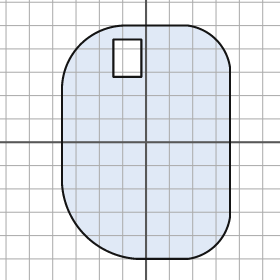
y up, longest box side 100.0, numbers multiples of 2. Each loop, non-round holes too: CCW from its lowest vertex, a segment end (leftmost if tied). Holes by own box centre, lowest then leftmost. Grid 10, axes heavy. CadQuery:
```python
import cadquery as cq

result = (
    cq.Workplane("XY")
    .moveTo(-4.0, -50.0)
    .lineTo(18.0, -50.0)
    .threePointArc((30.0, -44.0), (36.0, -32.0))
    .lineTo(36.0, 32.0)
    .threePointArc((30.0, 44.0), (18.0, 50.0))
    .lineTo(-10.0, 50.0)
    .threePointArc((-28.0, 42.0), (-36.0, 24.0))
    .lineTo(-36.0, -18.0)
    .threePointArc((-26.0, -40.0), (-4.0, -50.0))
    .close()
    .moveTo(-14.0, 28.0)
    .lineTo(-2.0, 28.0)
    .lineTo(-2.0, 44.0)
    .lineTo(-14.0, 44.0)
    .close()
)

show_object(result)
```